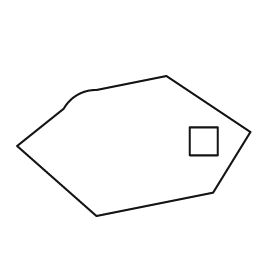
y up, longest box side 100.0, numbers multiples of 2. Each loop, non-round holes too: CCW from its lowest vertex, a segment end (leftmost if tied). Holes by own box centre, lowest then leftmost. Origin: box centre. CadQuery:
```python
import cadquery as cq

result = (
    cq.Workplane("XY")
    .moveTo(-16.0, -30.0)
    .lineTo(34.0, -20.0)
    .lineTo(50.0, 6.0)
    .lineTo(14.0, 30.0)
    .lineTo(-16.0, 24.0)
    .threePointArc((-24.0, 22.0), (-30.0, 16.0))
    .lineTo(-50.0, 0.0)
    .close()
    .moveTo(24.0, -4.0)
    .lineTo(36.0, -4.0)
    .lineTo(36.0, 8.0)
    .lineTo(24.0, 8.0)
    .close()
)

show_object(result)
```